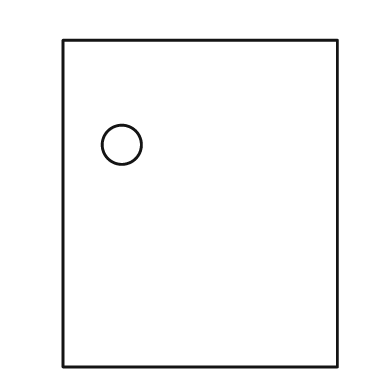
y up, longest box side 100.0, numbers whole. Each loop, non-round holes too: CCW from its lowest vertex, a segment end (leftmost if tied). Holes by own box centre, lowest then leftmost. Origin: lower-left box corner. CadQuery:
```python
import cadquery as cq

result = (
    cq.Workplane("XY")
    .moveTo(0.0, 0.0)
    .lineTo(84.0, 0.0)
    .lineTo(84.0, 100.0)
    .lineTo(0.0, 100.0)
    .close()
    .moveTo(18.0, 68.0)
    .circle(6.0)
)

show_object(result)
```